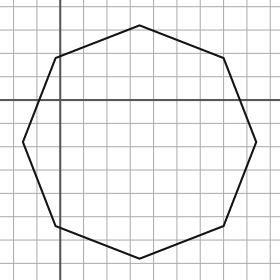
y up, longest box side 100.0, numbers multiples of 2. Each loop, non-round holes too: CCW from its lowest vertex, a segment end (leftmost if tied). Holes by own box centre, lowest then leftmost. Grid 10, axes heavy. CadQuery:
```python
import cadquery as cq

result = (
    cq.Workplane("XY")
    .moveTo(34.0, -68.0)
    .lineTo(70.0, -54.0)
    .lineTo(84.0, -18.0)
    .lineTo(70.0, 18.0)
    .lineTo(34.0, 32.0)
    .lineTo(-2.0, 18.0)
    .lineTo(-16.0, -18.0)
    .lineTo(-2.0, -54.0)
    .close()
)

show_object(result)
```